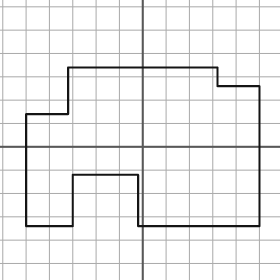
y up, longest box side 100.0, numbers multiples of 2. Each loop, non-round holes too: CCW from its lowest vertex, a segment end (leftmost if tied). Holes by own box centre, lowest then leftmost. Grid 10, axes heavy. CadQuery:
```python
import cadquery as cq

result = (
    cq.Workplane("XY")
    .moveTo(-50.0, -34.0)
    .lineTo(-30.0, -34.0)
    .lineTo(-30.0, -12.0)
    .lineTo(-2.0, -12.0)
    .lineTo(-2.0, -34.0)
    .lineTo(50.0, -34.0)
    .lineTo(50.0, 26.0)
    .lineTo(32.0, 26.0)
    .lineTo(32.0, 34.0)
    .lineTo(-32.0, 34.0)
    .lineTo(-32.0, 14.0)
    .lineTo(-50.0, 14.0)
    .close()
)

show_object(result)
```